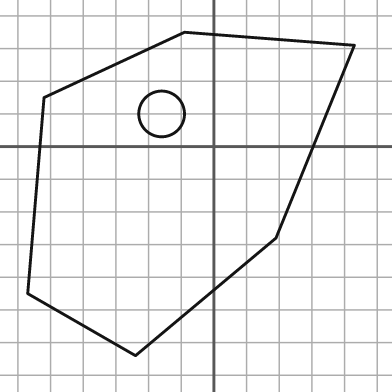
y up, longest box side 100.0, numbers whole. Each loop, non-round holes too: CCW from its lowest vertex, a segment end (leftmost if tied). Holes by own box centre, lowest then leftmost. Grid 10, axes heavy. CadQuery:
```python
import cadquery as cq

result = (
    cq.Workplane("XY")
    .moveTo(-24.0, -64.0)
    .lineTo(19.0, -28.0)
    .lineTo(43.0, 31.0)
    .lineTo(-9.0, 35.0)
    .lineTo(-52.0, 15.0)
    .lineTo(-57.0, -45.0)
    .close()
    .moveTo(-16.0, 10.0)
    .circle(7.0)
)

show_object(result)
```